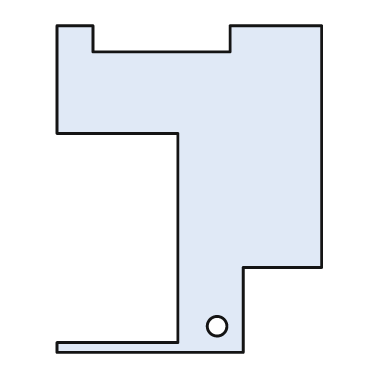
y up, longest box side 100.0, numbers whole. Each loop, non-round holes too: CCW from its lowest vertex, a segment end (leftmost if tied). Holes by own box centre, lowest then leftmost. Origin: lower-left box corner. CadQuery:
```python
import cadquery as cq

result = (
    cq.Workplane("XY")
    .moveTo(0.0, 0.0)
    .lineTo(57.0, 0.0)
    .lineTo(57.0, 26.0)
    .lineTo(81.0, 26.0)
    .lineTo(81.0, 100.0)
    .lineTo(53.0, 100.0)
    .lineTo(53.0, 92.0)
    .lineTo(11.0, 92.0)
    .lineTo(11.0, 100.0)
    .lineTo(0.0, 100.0)
    .lineTo(0.0, 67.0)
    .lineTo(37.0, 67.0)
    .lineTo(37.0, 3.0)
    .lineTo(0.0, 3.0)
    .close()
    .moveTo(49.0, 8.0)
    .circle(3.0)
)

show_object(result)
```